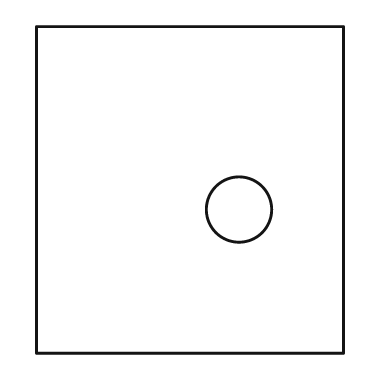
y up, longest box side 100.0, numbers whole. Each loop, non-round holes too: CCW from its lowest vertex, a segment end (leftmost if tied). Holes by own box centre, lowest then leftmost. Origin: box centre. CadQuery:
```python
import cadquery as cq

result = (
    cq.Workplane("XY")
    .moveTo(-47.0, -50.0)
    .lineTo(47.0, -50.0)
    .lineTo(47.0, 50.0)
    .lineTo(-47.0, 50.0)
    .close()
    .moveTo(15.0, -6.0)
    .circle(10.0)
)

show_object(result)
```